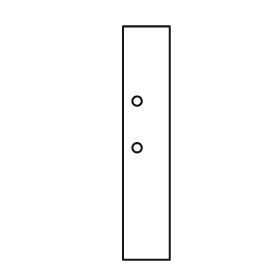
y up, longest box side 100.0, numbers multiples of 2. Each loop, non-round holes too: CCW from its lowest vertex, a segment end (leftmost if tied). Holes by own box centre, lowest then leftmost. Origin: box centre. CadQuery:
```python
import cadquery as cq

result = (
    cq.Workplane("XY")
    .moveTo(-10.0, -50.0)
    .lineTo(10.0, -50.0)
    .lineTo(10.0, 50.0)
    .lineTo(-10.0, 50.0)
    .close()
    .moveTo(-4.0, -2.0)
    .circle(2.0)
    .moveTo(-4.0, 18.0)
    .circle(2.0)
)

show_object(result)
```